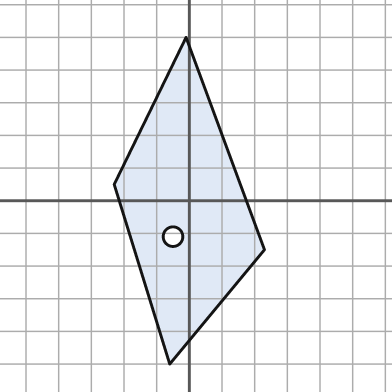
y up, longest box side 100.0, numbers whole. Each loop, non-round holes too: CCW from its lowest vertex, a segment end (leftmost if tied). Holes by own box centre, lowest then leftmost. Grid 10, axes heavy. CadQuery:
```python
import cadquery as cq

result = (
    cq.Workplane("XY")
    .moveTo(-6.0, -50.0)
    .lineTo(23.0, -15.0)
    .lineTo(-1.0, 50.0)
    .lineTo(-23.0, 5.0)
    .close()
    .moveTo(-5.0, -11.0)
    .circle(3.0)
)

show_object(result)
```